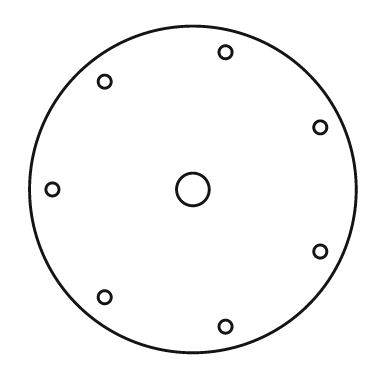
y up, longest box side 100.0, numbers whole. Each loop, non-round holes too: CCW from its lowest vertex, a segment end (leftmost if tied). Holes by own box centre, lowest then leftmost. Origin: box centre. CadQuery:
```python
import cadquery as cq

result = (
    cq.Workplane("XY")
    .moveTo(0.0, 0.0)
    .circle(50.0)
    .moveTo(10.0, -42.0)
    .circle(2.0)
    .moveTo(-27.0, -33.0)
    .circle(2.0)
    .moveTo(39.0, -19.0)
    .circle(2.0)
    .moveTo(-43.0, 0.0)
    .circle(2.0)
    .moveTo(0.0, 0.0)
    .circle(5.0)
    .moveTo(39.0, 19.0)
    .circle(2.0)
    .moveTo(-27.0, 33.0)
    .circle(2.0)
    .moveTo(10.0, 42.0)
    .circle(2.0)
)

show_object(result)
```